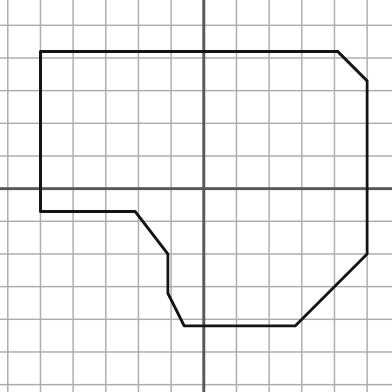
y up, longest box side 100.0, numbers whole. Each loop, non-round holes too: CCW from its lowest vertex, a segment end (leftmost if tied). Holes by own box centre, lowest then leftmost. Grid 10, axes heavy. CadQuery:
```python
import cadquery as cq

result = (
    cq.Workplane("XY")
    .moveTo(-6.0, -42.0)
    .lineTo(28.0, -42.0)
    .lineTo(50.0, -20.0)
    .lineTo(50.0, 33.0)
    .lineTo(41.0, 42.0)
    .lineTo(-50.0, 42.0)
    .lineTo(-50.0, -7.0)
    .lineTo(-21.0, -7.0)
    .lineTo(-11.0, -20.0)
    .lineTo(-11.0, -32.0)
    .close()
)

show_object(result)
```